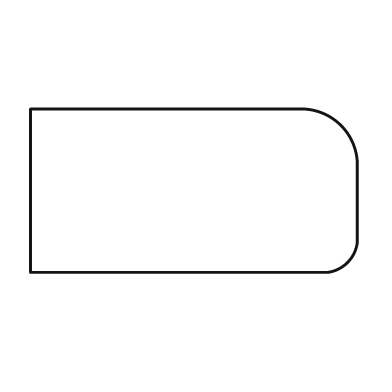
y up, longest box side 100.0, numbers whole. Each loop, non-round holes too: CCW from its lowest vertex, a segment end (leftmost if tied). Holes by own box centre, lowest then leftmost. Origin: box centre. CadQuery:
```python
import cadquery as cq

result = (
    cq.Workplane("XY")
    .moveTo(-50.0, -25.0)
    .lineTo(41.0, -25.0)
    .threePointArc((47.0, -22.0), (50.0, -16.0))
    .lineTo(50.0, 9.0)
    .threePointArc((45.0, 20.0), (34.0, 25.0))
    .lineTo(-50.0, 25.0)
    .close()
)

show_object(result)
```